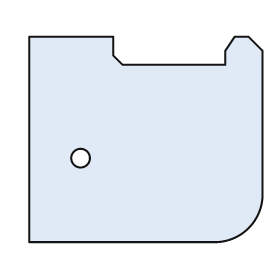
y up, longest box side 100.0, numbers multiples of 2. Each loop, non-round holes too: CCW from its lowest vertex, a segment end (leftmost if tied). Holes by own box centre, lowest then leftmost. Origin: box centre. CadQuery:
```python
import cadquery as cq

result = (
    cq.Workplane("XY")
    .moveTo(-50.0, -44.0)
    .lineTo(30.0, -44.0)
    .threePointArc((44.0, -38.0), (50.0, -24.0))
    .lineTo(50.0, 38.0)
    .lineTo(44.0, 44.0)
    .lineTo(38.0, 44.0)
    .lineTo(34.0, 38.0)
    .lineTo(34.0, 32.0)
    .lineTo(-10.0, 32.0)
    .lineTo(-14.0, 36.0)
    .lineTo(-14.0, 44.0)
    .lineTo(-50.0, 44.0)
    .close()
    .moveTo(-28.0, -8.0)
    .circle(4.0)
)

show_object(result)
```